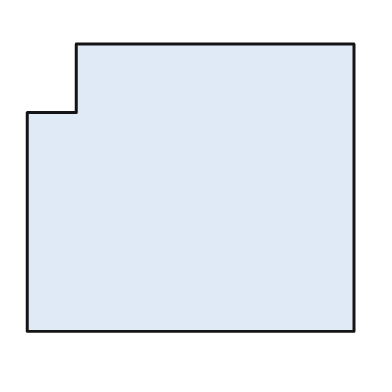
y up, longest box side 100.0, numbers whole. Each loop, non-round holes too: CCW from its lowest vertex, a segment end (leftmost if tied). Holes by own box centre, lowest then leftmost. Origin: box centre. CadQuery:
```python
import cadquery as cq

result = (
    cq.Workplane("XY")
    .moveTo(-50.0, -44.0)
    .lineTo(50.0, -44.0)
    .lineTo(50.0, 44.0)
    .lineTo(-35.0, 44.0)
    .lineTo(-35.0, 23.0)
    .lineTo(-50.0, 23.0)
    .close()
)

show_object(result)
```